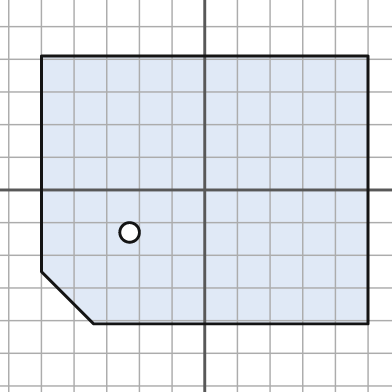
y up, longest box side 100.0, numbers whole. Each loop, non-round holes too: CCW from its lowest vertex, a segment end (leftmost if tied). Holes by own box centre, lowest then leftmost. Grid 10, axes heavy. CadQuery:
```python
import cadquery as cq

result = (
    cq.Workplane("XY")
    .moveTo(-34.0, -41.0)
    .lineTo(50.0, -41.0)
    .lineTo(50.0, 41.0)
    .lineTo(-50.0, 41.0)
    .lineTo(-50.0, -25.0)
    .close()
    .moveTo(-23.0, -13.0)
    .circle(3.0)
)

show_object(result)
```